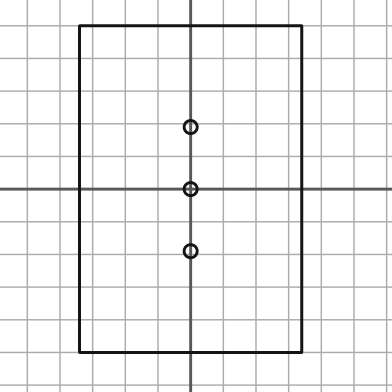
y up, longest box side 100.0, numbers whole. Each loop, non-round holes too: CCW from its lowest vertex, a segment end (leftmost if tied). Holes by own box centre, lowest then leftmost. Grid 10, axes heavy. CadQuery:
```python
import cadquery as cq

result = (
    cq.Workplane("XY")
    .moveTo(-34.0, -50.0)
    .lineTo(34.0, -50.0)
    .lineTo(34.0, 50.0)
    .lineTo(-34.0, 50.0)
    .close()
    .moveTo(0.0, -19.0)
    .circle(2.0)
    .moveTo(0.0, 0.0)
    .circle(2.0)
    .moveTo(0.0, 19.0)
    .circle(2.0)
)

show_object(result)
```